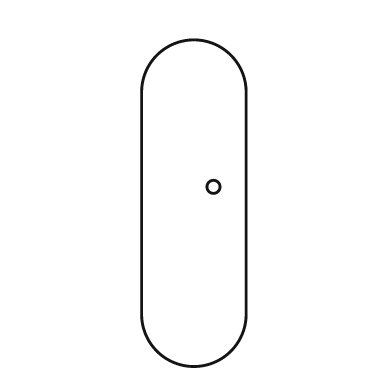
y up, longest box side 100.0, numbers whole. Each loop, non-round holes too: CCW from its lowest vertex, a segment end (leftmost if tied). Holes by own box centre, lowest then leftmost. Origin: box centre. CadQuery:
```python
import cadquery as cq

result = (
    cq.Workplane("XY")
    .moveTo(-16.0, -34.0)
    .threePointArc((0.0, -50.0), (16.0, -34.0))
    .lineTo(16.0, 34.0)
    .threePointArc((0.0, 50.0), (-16.0, 34.0))
    .close()
    .moveTo(6.0, 5.0)
    .circle(2.0)
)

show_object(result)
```